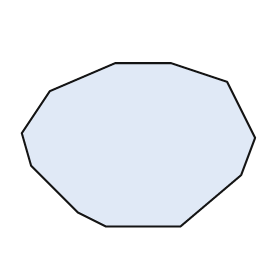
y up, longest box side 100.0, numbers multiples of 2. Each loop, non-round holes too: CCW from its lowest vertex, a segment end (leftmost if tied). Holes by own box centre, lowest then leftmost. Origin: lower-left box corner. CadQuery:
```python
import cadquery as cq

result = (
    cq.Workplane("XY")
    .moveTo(36.0, 0.0)
    .lineTo(68.0, 0.0)
    .lineTo(94.0, 22.0)
    .lineTo(100.0, 38.0)
    .lineTo(88.0, 62.0)
    .lineTo(64.0, 70.0)
    .lineTo(40.0, 70.0)
    .lineTo(12.0, 58.0)
    .lineTo(0.0, 40.0)
    .lineTo(4.0, 26.0)
    .lineTo(24.0, 6.0)
    .close()
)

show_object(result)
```